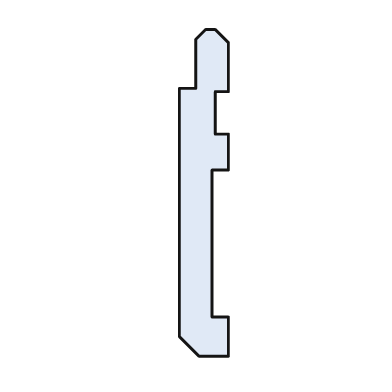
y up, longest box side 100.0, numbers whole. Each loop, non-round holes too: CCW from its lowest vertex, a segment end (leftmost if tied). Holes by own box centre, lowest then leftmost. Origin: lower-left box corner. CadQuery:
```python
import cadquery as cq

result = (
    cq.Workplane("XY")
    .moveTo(6.0, 0.0)
    .lineTo(15.0, 0.0)
    .lineTo(15.0, 12.0)
    .lineTo(10.0, 12.0)
    .lineTo(10.0, 57.0)
    .lineTo(15.0, 57.0)
    .lineTo(15.0, 68.0)
    .lineTo(11.0, 68.0)
    .lineTo(11.0, 81.0)
    .lineTo(15.0, 81.0)
    .lineTo(15.0, 96.0)
    .lineTo(11.0, 100.0)
    .lineTo(8.0, 100.0)
    .lineTo(5.0, 97.0)
    .lineTo(5.0, 82.0)
    .lineTo(0.0, 82.0)
    .lineTo(0.0, 6.0)
    .close()
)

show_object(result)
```